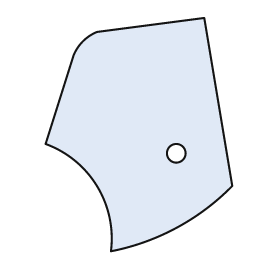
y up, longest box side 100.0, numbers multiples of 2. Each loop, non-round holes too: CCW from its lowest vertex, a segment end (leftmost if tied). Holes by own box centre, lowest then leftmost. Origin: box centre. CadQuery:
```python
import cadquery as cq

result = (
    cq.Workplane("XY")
    .moveTo(-12.0, -50.0)
    .threePointArc((16.0, -40.0), (40.0, -22.0))
    .lineTo(28.0, 50.0)
    .lineTo(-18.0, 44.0)
    .threePointArc((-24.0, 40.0), (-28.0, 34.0))
    .lineTo(-40.0, -4.0)
    .threePointArc((-18.0, -22.0), (-12.0, -50.0))
    .close()
    .moveTo(16.0, -8.0)
    .circle(4.0)
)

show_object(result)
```